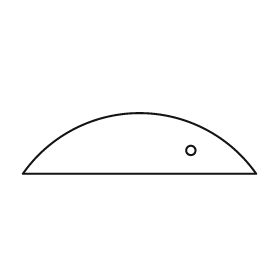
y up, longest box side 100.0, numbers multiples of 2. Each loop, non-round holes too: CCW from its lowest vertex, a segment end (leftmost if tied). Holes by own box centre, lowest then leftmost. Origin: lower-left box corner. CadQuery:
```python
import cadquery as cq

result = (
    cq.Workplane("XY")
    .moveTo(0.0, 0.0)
    .lineTo(100.0, 0.0)
    .threePointArc((50.0, 26.0), (0.0, 0.0))
    .close()
    .moveTo(72.0, 10.0)
    .circle(2.0)
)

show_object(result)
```